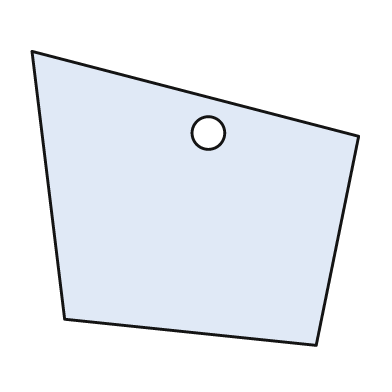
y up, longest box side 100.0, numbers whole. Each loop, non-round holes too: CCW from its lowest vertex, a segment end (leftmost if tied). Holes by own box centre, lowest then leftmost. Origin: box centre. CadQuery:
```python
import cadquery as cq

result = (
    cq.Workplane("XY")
    .moveTo(37.0, -45.0)
    .lineTo(50.0, 19.0)
    .lineTo(-50.0, 45.0)
    .lineTo(-40.0, -37.0)
    .close()
    .moveTo(4.0, 20.0)
    .circle(5.0)
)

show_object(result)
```